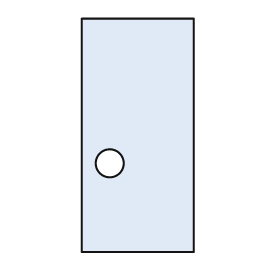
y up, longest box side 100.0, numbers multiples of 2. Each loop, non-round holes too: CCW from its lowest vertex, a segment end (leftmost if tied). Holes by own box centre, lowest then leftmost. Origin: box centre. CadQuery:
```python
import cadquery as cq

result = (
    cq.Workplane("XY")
    .moveTo(-24.0, -50.0)
    .lineTo(24.0, -50.0)
    .lineTo(24.0, 50.0)
    .lineTo(-24.0, 50.0)
    .close()
    .moveTo(-12.0, -12.0)
    .circle(6.0)
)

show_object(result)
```